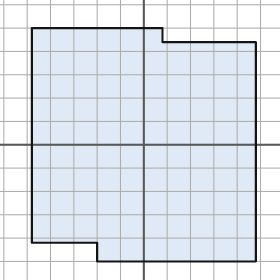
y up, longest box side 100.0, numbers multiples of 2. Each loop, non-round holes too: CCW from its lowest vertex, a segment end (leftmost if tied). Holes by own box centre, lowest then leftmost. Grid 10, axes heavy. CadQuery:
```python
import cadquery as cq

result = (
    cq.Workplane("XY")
    .moveTo(-20.0, -50.0)
    .lineTo(48.0, -50.0)
    .lineTo(48.0, 44.0)
    .lineTo(8.0, 44.0)
    .lineTo(8.0, 50.0)
    .lineTo(-48.0, 50.0)
    .lineTo(-48.0, -42.0)
    .lineTo(-20.0, -42.0)
    .close()
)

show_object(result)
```